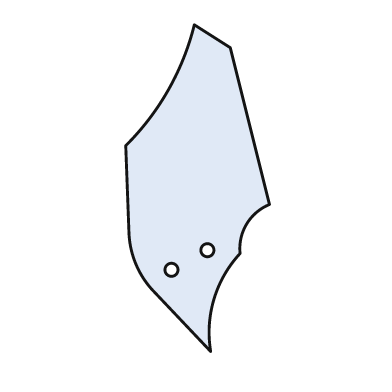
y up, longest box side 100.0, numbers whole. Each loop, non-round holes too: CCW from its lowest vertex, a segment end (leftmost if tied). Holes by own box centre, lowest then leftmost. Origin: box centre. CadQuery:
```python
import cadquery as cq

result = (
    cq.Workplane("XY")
    .moveTo(4.0, -50.0)
    .threePointArc((5.0, -34.0), (13.0, -20.0))
    .threePointArc((15.0, -11.0), (22.0, -5.0))
    .lineTo(10.0, 43.0)
    .lineTo(-1.0, 50.0)
    .threePointArc((-9.0, 30.0), (-22.0, 13.0))
    .lineTo(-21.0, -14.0)
    .threePointArc((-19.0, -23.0), (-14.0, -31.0))
    .close()
    .moveTo(-8.0, -25.0)
    .circle(2.0)
    .moveTo(3.0, -19.0)
    .circle(2.0)
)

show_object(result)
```